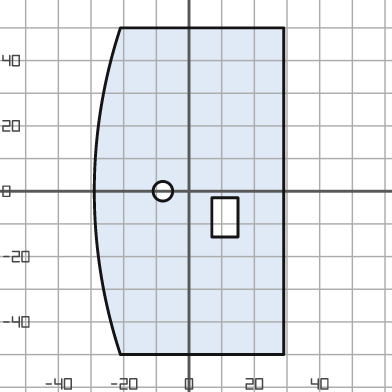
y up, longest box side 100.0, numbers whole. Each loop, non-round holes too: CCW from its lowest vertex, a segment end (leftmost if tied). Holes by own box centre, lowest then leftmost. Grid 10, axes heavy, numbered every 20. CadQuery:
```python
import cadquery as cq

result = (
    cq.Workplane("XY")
    .moveTo(-21.0, -50.0)
    .lineTo(29.0, -50.0)
    .lineTo(29.0, 50.0)
    .lineTo(-21.0, 50.0)
    .threePointArc((-29.0, 0.0), (-21.0, -50.0))
    .close()
    .moveTo(7.0, -14.0)
    .lineTo(15.0, -14.0)
    .lineTo(15.0, -2.0)
    .lineTo(7.0, -2.0)
    .close()
    .moveTo(-8.0, 0.0)
    .circle(3.0)
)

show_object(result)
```